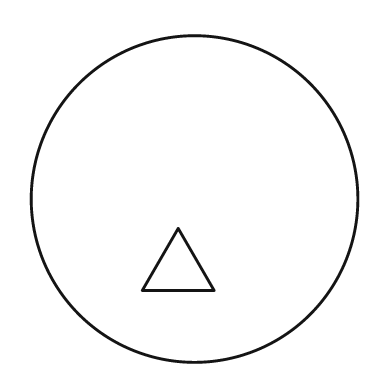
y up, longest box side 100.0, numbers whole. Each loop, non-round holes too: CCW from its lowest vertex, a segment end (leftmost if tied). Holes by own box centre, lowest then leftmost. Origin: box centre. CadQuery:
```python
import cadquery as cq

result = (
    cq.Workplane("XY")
    .moveTo(0.0, 0.0)
    .circle(50.0)
    .moveTo(-16.0, -28.0)
    .lineTo(6.0, -28.0)
    .lineTo(-5.0, -9.0)
    .close()
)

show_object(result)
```